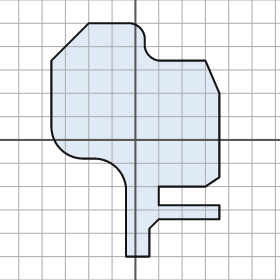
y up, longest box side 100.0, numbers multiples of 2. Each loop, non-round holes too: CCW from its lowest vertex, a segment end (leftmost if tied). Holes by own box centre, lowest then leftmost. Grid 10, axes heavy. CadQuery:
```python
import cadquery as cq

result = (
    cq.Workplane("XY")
    .moveTo(-4.0, -50.0)
    .lineTo(6.0, -50.0)
    .lineTo(6.0, -38.0)
    .lineTo(10.0, -34.0)
    .lineTo(36.0, -34.0)
    .lineTo(36.0, -28.0)
    .lineTo(10.0, -28.0)
    .lineTo(10.0, -20.0)
    .lineTo(30.0, -20.0)
    .lineTo(36.0, -16.0)
    .lineTo(36.0, 20.0)
    .lineTo(30.0, 34.0)
    .lineTo(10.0, 34.0)
    .threePointArc((6.0, 36.0), (4.0, 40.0))
    .lineTo(4.0, 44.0)
    .threePointArc((2.0, 48.0), (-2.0, 50.0))
    .lineTo(-20.0, 50.0)
    .lineTo(-36.0, 34.0)
    .lineTo(-36.0, 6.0)
    .threePointArc((-32.0, -4.0), (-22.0, -8.0))
    .lineTo(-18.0, -8.0)
    .threePointArc((-8.0, -12.0), (-4.0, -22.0))
    .close()
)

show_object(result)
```